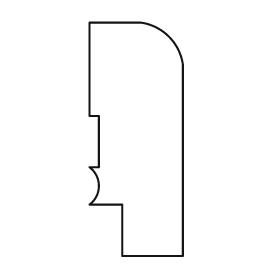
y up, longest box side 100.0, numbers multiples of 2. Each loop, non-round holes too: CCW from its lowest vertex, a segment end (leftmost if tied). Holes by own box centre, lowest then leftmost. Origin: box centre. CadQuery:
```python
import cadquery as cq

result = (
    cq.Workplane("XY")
    .moveTo(-6.0, -50.0)
    .lineTo(20.0, -50.0)
    .lineTo(20.0, 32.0)
    .threePointArc((14.0, 44.0), (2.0, 50.0))
    .lineTo(-20.0, 50.0)
    .lineTo(-20.0, 10.0)
    .lineTo(-16.0, 10.0)
    .lineTo(-16.0, -12.0)
    .lineTo(-20.0, -12.0)
    .threePointArc((-16.0, -20.0), (-20.0, -28.0))
    .lineTo(-6.0, -28.0)
    .close()
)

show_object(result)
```